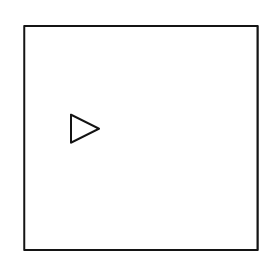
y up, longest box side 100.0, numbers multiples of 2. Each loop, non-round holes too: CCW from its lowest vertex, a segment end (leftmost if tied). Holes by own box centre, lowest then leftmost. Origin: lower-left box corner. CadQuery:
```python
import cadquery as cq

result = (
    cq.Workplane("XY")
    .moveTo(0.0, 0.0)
    .lineTo(100.0, 0.0)
    .lineTo(100.0, 96.0)
    .lineTo(0.0, 96.0)
    .close()
    .moveTo(20.0, 46.0)
    .lineTo(32.0, 52.0)
    .lineTo(20.0, 58.0)
    .close()
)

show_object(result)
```